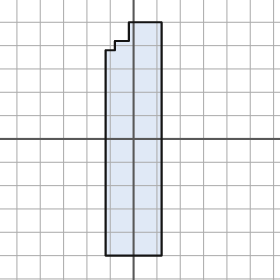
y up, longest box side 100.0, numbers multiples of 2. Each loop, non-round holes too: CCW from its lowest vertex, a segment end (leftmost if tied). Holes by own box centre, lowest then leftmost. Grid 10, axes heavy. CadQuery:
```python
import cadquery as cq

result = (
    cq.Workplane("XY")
    .moveTo(-12.0, -50.0)
    .lineTo(12.0, -50.0)
    .lineTo(12.0, 50.0)
    .lineTo(-2.0, 50.0)
    .lineTo(-2.0, 42.0)
    .lineTo(-8.0, 42.0)
    .lineTo(-8.0, 38.0)
    .lineTo(-12.0, 38.0)
    .close()
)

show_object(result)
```